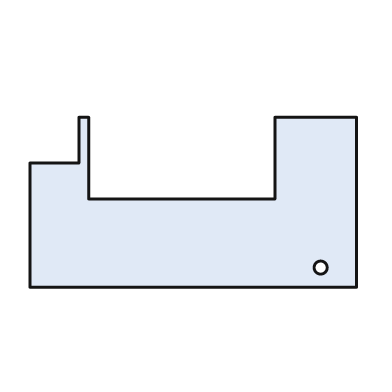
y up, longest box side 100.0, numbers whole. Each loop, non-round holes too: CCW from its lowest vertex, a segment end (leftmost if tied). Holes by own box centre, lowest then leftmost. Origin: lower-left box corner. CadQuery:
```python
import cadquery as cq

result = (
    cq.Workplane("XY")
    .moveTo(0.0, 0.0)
    .lineTo(100.0, 0.0)
    .lineTo(100.0, 52.0)
    .lineTo(75.0, 52.0)
    .lineTo(75.0, 27.0)
    .lineTo(18.0, 27.0)
    .lineTo(18.0, 52.0)
    .lineTo(15.0, 52.0)
    .lineTo(15.0, 38.0)
    .lineTo(0.0, 38.0)
    .close()
    .moveTo(89.0, 6.0)
    .circle(2.0)
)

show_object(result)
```